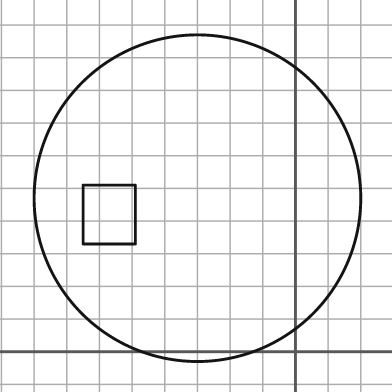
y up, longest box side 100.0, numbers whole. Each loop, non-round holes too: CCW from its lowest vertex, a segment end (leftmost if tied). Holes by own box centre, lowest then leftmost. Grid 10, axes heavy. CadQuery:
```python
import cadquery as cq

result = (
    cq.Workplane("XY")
    .moveTo(-30.0, 47.0)
    .circle(50.0)
    .moveTo(-65.0, 33.0)
    .lineTo(-49.0, 33.0)
    .lineTo(-49.0, 51.0)
    .lineTo(-65.0, 51.0)
    .close()
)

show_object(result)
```